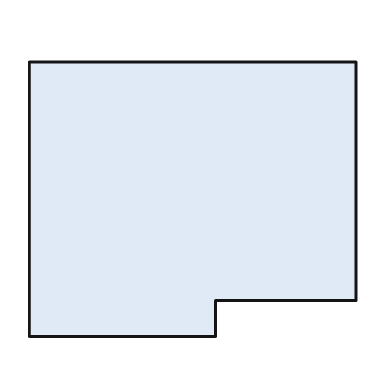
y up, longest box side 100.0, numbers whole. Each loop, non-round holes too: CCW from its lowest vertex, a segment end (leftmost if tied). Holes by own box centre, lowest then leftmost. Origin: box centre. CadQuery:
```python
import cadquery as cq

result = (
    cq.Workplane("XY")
    .moveTo(-50.0, -42.0)
    .lineTo(7.0, -42.0)
    .lineTo(7.0, -31.0)
    .lineTo(50.0, -31.0)
    .lineTo(50.0, 42.0)
    .lineTo(-50.0, 42.0)
    .close()
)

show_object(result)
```